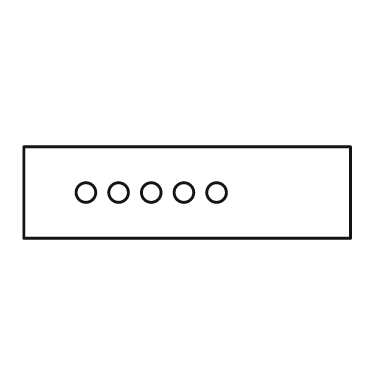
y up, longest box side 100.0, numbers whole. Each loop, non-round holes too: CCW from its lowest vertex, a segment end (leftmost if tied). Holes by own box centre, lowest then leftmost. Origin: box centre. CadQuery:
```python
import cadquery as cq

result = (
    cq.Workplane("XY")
    .moveTo(-50.0, -14.0)
    .lineTo(50.0, -14.0)
    .lineTo(50.0, 14.0)
    .lineTo(-50.0, 14.0)
    .close()
    .moveTo(-31.0, 0.0)
    .circle(3.0)
    .moveTo(-21.0, 0.0)
    .circle(3.0)
    .moveTo(-11.0, 0.0)
    .circle(3.0)
    .moveTo(-1.0, 0.0)
    .circle(3.0)
    .moveTo(9.0, 0.0)
    .circle(3.0)
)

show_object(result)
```